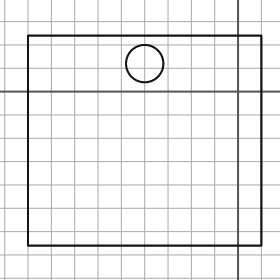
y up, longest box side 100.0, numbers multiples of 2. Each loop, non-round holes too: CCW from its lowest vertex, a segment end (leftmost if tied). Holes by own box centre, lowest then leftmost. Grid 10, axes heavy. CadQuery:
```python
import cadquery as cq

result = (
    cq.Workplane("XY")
    .moveTo(-90.0, -66.0)
    .lineTo(10.0, -66.0)
    .lineTo(10.0, 24.0)
    .lineTo(-90.0, 24.0)
    .close()
    .moveTo(-40.0, 12.0)
    .circle(8.0)
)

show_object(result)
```